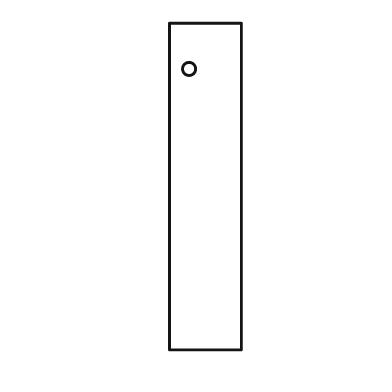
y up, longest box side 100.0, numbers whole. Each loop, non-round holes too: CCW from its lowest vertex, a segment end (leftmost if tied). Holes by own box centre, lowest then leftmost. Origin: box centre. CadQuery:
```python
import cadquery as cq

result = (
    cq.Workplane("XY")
    .moveTo(-11.0, -50.0)
    .lineTo(11.0, -50.0)
    .lineTo(11.0, 50.0)
    .lineTo(-11.0, 50.0)
    .close()
    .moveTo(-5.0, 36.0)
    .circle(2.0)
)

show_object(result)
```